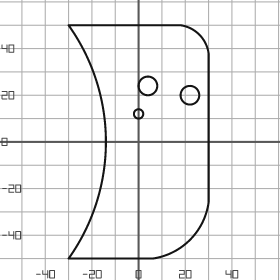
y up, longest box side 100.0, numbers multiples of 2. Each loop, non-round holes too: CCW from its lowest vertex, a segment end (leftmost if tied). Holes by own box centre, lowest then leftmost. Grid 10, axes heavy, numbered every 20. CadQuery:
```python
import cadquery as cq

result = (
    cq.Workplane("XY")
    .moveTo(-30.0, -50.0)
    .lineTo(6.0, -50.0)
    .threePointArc((22.0, -42.0), (30.0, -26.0))
    .lineTo(30.0, 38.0)
    .threePointArc((26.0, 46.0), (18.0, 50.0))
    .lineTo(-30.0, 50.0)
    .threePointArc((-14.0, 0.0), (-30.0, -50.0))
    .close()
    .moveTo(0.0, 12.0)
    .circle(2.0)
    .moveTo(22.0, 20.0)
    .circle(4.0)
    .moveTo(4.0, 24.0)
    .circle(4.0)
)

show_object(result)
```